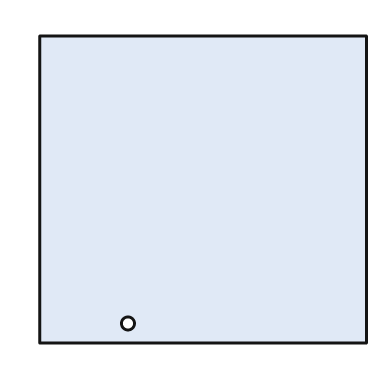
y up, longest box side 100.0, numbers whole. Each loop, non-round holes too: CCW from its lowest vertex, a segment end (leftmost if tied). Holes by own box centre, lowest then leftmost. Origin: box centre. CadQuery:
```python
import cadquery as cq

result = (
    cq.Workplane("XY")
    .moveTo(-50.0, -47.0)
    .lineTo(50.0, -47.0)
    .lineTo(50.0, 47.0)
    .lineTo(-50.0, 47.0)
    .close()
    .moveTo(-23.0, -41.0)
    .circle(2.0)
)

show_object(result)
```